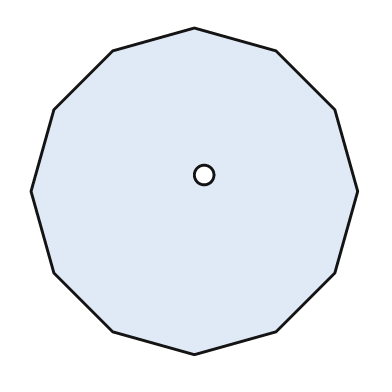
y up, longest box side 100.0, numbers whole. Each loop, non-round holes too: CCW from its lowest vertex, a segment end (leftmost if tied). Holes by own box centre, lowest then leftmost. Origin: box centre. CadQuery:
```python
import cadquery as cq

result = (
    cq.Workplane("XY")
    .moveTo(0.0, -50.0)
    .lineTo(25.0, -43.0)
    .lineTo(43.0, -25.0)
    .lineTo(50.0, 0.0)
    .lineTo(43.0, 25.0)
    .lineTo(25.0, 43.0)
    .lineTo(0.0, 50.0)
    .lineTo(-25.0, 43.0)
    .lineTo(-43.0, 25.0)
    .lineTo(-50.0, 0.0)
    .lineTo(-43.0, -25.0)
    .lineTo(-25.0, -43.0)
    .close()
    .moveTo(3.0, 5.0)
    .circle(3.0)
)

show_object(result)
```